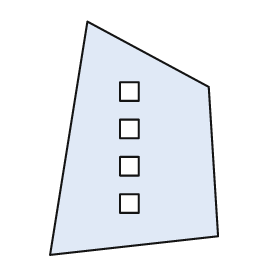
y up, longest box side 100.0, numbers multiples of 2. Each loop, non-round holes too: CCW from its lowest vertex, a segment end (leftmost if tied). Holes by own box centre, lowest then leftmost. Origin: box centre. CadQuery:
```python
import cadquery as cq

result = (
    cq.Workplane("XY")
    .moveTo(-36.0, -50.0)
    .lineTo(36.0, -42.0)
    .lineTo(32.0, 22.0)
    .lineTo(-20.0, 50.0)
    .close()
    .moveTo(-6.0, -32.0)
    .lineTo(2.0, -32.0)
    .lineTo(2.0, -24.0)
    .lineTo(-6.0, -24.0)
    .close()
    .moveTo(-6.0, -16.0)
    .lineTo(2.0, -16.0)
    .lineTo(2.0, -8.0)
    .lineTo(-6.0, -8.0)
    .close()
    .moveTo(-6.0, 0.0)
    .lineTo(2.0, 0.0)
    .lineTo(2.0, 8.0)
    .lineTo(-6.0, 8.0)
    .close()
    .moveTo(-6.0, 16.0)
    .lineTo(2.0, 16.0)
    .lineTo(2.0, 24.0)
    .lineTo(-6.0, 24.0)
    .close()
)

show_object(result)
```